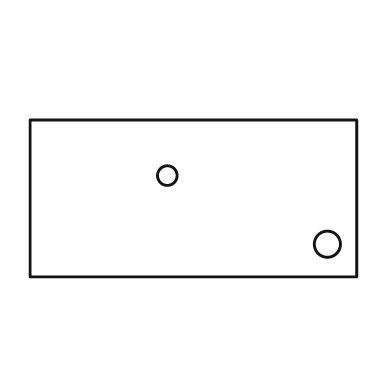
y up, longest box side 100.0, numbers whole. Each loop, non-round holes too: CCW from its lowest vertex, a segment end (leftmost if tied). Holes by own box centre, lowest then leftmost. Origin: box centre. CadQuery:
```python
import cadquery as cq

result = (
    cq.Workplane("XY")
    .moveTo(-50.0, -24.0)
    .lineTo(50.0, -24.0)
    .lineTo(50.0, 24.0)
    .lineTo(-50.0, 24.0)
    .close()
    .moveTo(41.0, -14.0)
    .circle(4.0)
    .moveTo(-8.0, 7.0)
    .circle(3.0)
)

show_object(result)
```